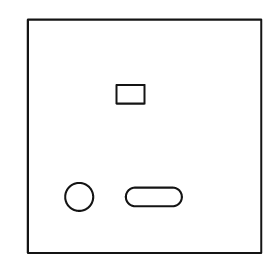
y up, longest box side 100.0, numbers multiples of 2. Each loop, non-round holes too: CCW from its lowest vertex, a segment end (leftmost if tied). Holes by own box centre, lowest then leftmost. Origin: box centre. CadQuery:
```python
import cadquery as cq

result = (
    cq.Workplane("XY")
    .moveTo(-50.0, -50.0)
    .lineTo(50.0, -50.0)
    .lineTo(50.0, 50.0)
    .lineTo(-50.0, 50.0)
    .close()
    .moveTo(-28.0, -26.0)
    .circle(6.0)
    .moveTo(-4.0, -30.0)
    .lineTo(12.0, -30.0)
    .threePointArc((16.0, -26.0), (12.0, -22.0))
    .lineTo(-4.0, -22.0)
    .threePointArc((-8.0, -26.0), (-4.0, -30.0))
    .close()
    .moveTo(-12.0, 14.0)
    .lineTo(0.0, 14.0)
    .lineTo(0.0, 22.0)
    .lineTo(-12.0, 22.0)
    .close()
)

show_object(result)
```